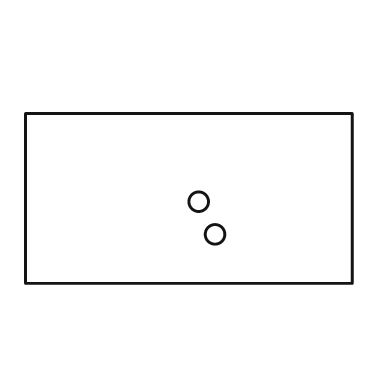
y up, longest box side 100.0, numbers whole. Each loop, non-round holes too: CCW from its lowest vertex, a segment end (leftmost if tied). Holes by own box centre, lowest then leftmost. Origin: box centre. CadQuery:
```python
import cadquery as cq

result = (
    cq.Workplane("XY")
    .moveTo(-50.0, -26.0)
    .lineTo(50.0, -26.0)
    .lineTo(50.0, 26.0)
    .lineTo(-50.0, 26.0)
    .close()
    .moveTo(8.0, -11.0)
    .circle(3.0)
    .moveTo(3.0, -1.0)
    .circle(3.0)
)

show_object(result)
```